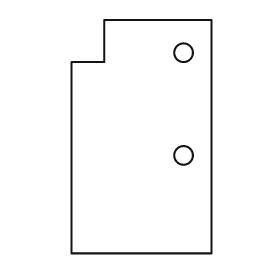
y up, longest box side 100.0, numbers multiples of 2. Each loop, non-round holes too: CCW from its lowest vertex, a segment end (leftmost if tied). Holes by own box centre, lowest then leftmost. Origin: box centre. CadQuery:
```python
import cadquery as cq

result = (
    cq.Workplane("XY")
    .moveTo(-30.0, -50.0)
    .lineTo(30.0, -50.0)
    .lineTo(30.0, 50.0)
    .lineTo(-16.0, 50.0)
    .lineTo(-16.0, 32.0)
    .lineTo(-30.0, 32.0)
    .close()
    .moveTo(18.0, -8.0)
    .circle(4.0)
    .moveTo(18.0, 36.0)
    .circle(4.0)
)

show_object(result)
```